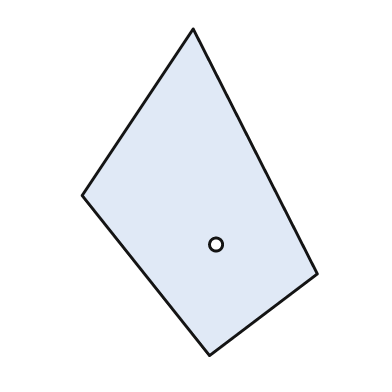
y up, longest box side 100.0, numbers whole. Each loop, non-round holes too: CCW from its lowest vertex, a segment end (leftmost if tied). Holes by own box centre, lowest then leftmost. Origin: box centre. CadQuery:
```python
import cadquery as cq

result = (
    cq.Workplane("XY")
    .moveTo(3.0, -50.0)
    .lineTo(36.0, -25.0)
    .lineTo(-2.0, 50.0)
    .lineTo(-36.0, -1.0)
    .close()
    .moveTo(5.0, -16.0)
    .circle(2.0)
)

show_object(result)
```